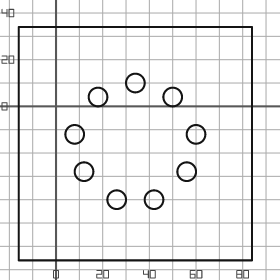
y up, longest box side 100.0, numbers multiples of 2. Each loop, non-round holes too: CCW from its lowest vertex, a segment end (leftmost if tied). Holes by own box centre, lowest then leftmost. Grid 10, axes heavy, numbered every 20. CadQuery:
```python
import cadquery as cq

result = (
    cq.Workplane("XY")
    .moveTo(-16.0, -66.0)
    .lineTo(84.0, -66.0)
    .lineTo(84.0, 34.0)
    .lineTo(-16.0, 34.0)
    .close()
    .moveTo(26.0, -40.0)
    .circle(4.0)
    .moveTo(42.0, -40.0)
    .circle(4.0)
    .moveTo(12.0, -28.0)
    .circle(4.0)
    .moveTo(56.0, -28.0)
    .circle(4.0)
    .moveTo(8.0, -12.0)
    .circle(4.0)
    .moveTo(60.0, -12.0)
    .circle(4.0)
    .moveTo(18.0, 4.0)
    .circle(4.0)
    .moveTo(50.0, 4.0)
    .circle(4.0)
    .moveTo(34.0, 10.0)
    .circle(4.0)
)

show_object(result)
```